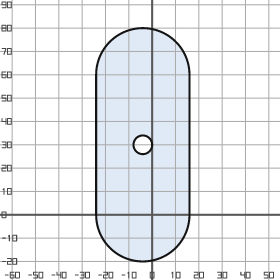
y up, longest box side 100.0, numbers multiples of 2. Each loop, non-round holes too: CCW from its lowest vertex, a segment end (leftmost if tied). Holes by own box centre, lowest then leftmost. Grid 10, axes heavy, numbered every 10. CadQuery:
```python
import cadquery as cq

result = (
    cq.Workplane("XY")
    .moveTo(-24.0, 0.0)
    .threePointArc((-4.0, -20.0), (16.0, 0.0))
    .lineTo(16.0, 60.0)
    .threePointArc((-4.0, 80.0), (-24.0, 60.0))
    .close()
    .moveTo(-4.0, 30.0)
    .circle(4.0)
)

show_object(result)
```